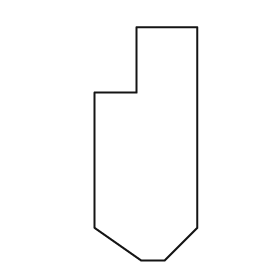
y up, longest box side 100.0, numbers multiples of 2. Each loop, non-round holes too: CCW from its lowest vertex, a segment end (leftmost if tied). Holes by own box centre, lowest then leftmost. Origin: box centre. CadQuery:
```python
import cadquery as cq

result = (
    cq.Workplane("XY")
    .moveTo(-2.0, -50.0)
    .lineTo(8.0, -50.0)
    .lineTo(22.0, -36.0)
    .lineTo(22.0, 50.0)
    .lineTo(-4.0, 50.0)
    .lineTo(-4.0, 22.0)
    .lineTo(-22.0, 22.0)
    .lineTo(-22.0, -36.0)
    .close()
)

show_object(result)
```